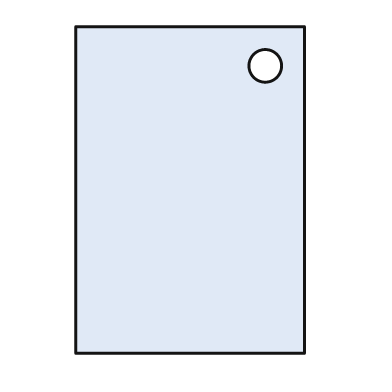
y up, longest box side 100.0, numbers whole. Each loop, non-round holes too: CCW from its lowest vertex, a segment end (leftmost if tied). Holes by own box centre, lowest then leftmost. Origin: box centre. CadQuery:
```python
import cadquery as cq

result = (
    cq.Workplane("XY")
    .moveTo(-35.0, -50.0)
    .lineTo(35.0, -50.0)
    .lineTo(35.0, 50.0)
    .lineTo(-35.0, 50.0)
    .close()
    .moveTo(23.0, 38.0)
    .circle(5.0)
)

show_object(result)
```